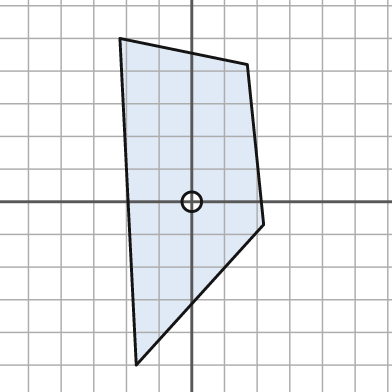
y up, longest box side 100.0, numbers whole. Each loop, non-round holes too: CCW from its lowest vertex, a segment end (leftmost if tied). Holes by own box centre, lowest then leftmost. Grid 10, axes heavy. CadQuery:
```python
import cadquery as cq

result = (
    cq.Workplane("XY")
    .moveTo(-17.0, -50.0)
    .lineTo(22.0, -7.0)
    .lineTo(17.0, 42.0)
    .lineTo(-22.0, 50.0)
    .close()
    .moveTo(0.0, 0.0)
    .circle(3.0)
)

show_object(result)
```